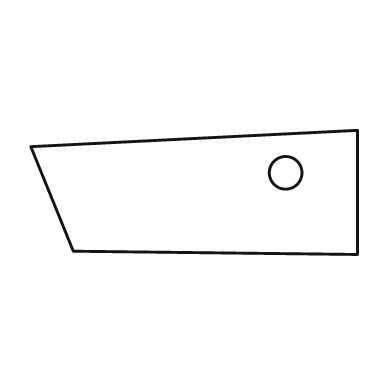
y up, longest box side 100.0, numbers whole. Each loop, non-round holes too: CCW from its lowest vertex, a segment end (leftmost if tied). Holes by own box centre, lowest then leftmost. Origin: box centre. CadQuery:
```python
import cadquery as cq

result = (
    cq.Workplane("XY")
    .moveTo(50.0, -19.0)
    .lineTo(50.0, 19.0)
    .lineTo(-50.0, 14.0)
    .lineTo(-37.0, -18.0)
    .close()
    .moveTo(28.0, 6.0)
    .circle(5.0)
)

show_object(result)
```